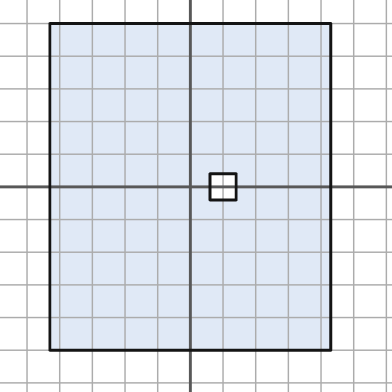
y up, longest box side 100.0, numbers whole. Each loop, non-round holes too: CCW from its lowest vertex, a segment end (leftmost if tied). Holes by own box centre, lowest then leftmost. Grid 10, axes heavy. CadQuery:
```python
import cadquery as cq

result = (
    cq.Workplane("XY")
    .moveTo(-43.0, -50.0)
    .lineTo(43.0, -50.0)
    .lineTo(43.0, 50.0)
    .lineTo(-43.0, 50.0)
    .close()
    .moveTo(6.0, -4.0)
    .lineTo(14.0, -4.0)
    .lineTo(14.0, 4.0)
    .lineTo(6.0, 4.0)
    .close()
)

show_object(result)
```